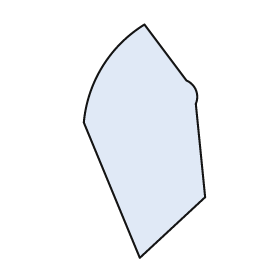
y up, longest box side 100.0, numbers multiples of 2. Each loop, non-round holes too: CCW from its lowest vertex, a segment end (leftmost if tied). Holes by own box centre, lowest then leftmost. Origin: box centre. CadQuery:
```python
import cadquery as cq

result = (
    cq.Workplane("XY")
    .moveTo(-2.0, -50.0)
    .lineTo(26.0, -24.0)
    .lineTo(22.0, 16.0)
    .threePointArc((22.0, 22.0), (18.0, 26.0))
    .lineTo(0.0, 50.0)
    .threePointArc((-18.0, 32.0), (-26.0, 8.0))
    .close()
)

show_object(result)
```